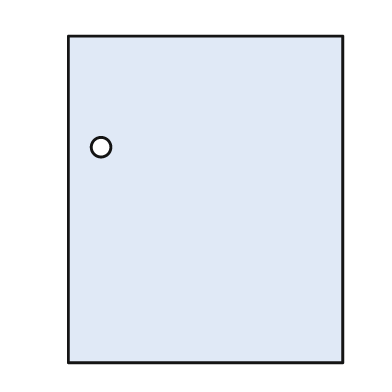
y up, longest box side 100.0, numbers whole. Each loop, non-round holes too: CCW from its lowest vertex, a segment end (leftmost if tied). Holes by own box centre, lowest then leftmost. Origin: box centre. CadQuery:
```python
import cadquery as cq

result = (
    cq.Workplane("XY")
    .moveTo(-42.0, -50.0)
    .lineTo(42.0, -50.0)
    .lineTo(42.0, 50.0)
    .lineTo(-42.0, 50.0)
    .close()
    .moveTo(-32.0, 16.0)
    .circle(3.0)
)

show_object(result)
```